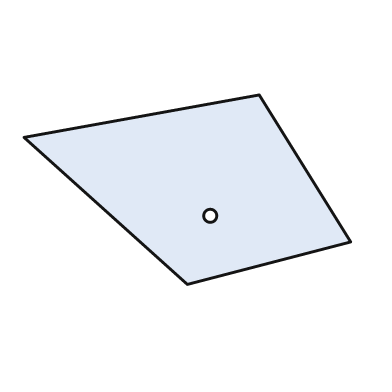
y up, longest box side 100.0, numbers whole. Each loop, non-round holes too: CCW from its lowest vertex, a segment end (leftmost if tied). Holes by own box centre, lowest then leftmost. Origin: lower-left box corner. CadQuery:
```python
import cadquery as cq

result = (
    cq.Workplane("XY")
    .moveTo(50.0, 0.0)
    .lineTo(100.0, 13.0)
    .lineTo(72.0, 58.0)
    .lineTo(0.0, 45.0)
    .close()
    .moveTo(57.0, 21.0)
    .circle(2.0)
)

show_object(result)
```